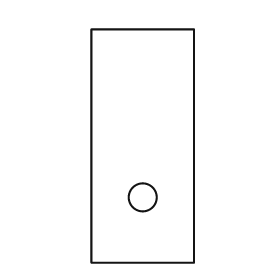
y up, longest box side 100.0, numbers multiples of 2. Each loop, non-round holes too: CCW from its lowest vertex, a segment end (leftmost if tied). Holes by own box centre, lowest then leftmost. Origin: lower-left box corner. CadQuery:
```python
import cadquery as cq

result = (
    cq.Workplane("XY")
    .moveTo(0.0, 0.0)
    .lineTo(44.0, 0.0)
    .lineTo(44.0, 100.0)
    .lineTo(0.0, 100.0)
    .close()
    .moveTo(22.0, 28.0)
    .circle(6.0)
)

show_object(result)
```